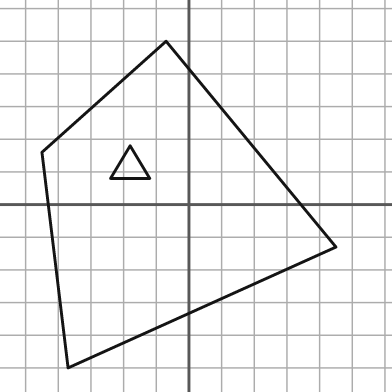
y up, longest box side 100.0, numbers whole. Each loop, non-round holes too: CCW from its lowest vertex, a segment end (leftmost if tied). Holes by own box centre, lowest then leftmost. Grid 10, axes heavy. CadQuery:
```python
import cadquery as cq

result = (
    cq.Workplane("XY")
    .moveTo(-37.0, -50.0)
    .lineTo(45.0, -13.0)
    .lineTo(-7.0, 50.0)
    .lineTo(-45.0, 16.0)
    .close()
    .moveTo(-24.0, 8.0)
    .lineTo(-12.0, 8.0)
    .lineTo(-18.0, 18.0)
    .close()
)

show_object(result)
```